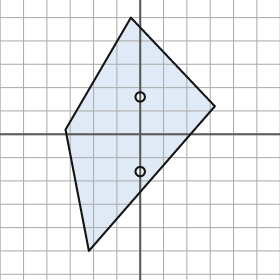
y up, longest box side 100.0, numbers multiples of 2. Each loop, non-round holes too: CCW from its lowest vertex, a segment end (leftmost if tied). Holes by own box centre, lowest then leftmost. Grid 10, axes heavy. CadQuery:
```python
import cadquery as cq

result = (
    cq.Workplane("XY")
    .moveTo(-22.0, -50.0)
    .lineTo(32.0, 12.0)
    .lineTo(-4.0, 50.0)
    .lineTo(-32.0, 2.0)
    .close()
    .moveTo(0.0, -16.0)
    .circle(2.0)
    .moveTo(0.0, 16.0)
    .circle(2.0)
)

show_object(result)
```